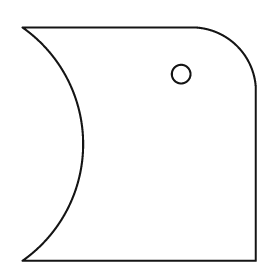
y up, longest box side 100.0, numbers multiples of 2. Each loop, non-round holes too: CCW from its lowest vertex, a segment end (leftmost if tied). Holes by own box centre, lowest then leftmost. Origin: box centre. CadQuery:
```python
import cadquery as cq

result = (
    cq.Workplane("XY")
    .moveTo(-50.0, -50.0)
    .lineTo(50.0, -50.0)
    .lineTo(50.0, 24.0)
    .threePointArc((42.0, 42.0), (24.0, 50.0))
    .lineTo(-50.0, 50.0)
    .threePointArc((-24.0, 0.0), (-50.0, -50.0))
    .close()
    .moveTo(18.0, 30.0)
    .circle(4.0)
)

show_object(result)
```